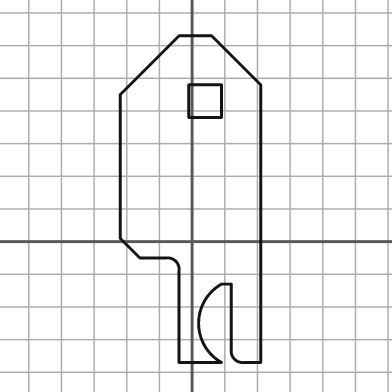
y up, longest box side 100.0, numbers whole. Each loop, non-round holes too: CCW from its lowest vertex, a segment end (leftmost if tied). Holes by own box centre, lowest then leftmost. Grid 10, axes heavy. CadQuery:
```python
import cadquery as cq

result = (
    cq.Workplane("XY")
    .moveTo(-4.0, -37.0)
    .lineTo(9.0, -37.0)
    .threePointArc((2.0, -25.0), (9.0, -13.0))
    .lineTo(12.0, -13.0)
    .lineTo(12.0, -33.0)
    .threePointArc((13.0, -36.0), (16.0, -37.0))
    .lineTo(21.0, -37.0)
    .lineTo(21.0, 48.0)
    .lineTo(6.0, 63.0)
    .lineTo(-4.0, 63.0)
    .lineTo(-22.0, 45.0)
    .lineTo(-22.0, 1.0)
    .lineTo(-16.0, -5.0)
    .lineTo(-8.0, -5.0)
    .threePointArc((-5.0, -6.0), (-4.0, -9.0))
    .close()
    .moveTo(-1.0, 38.0)
    .lineTo(9.0, 38.0)
    .lineTo(9.0, 48.0)
    .lineTo(-1.0, 48.0)
    .close()
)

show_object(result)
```